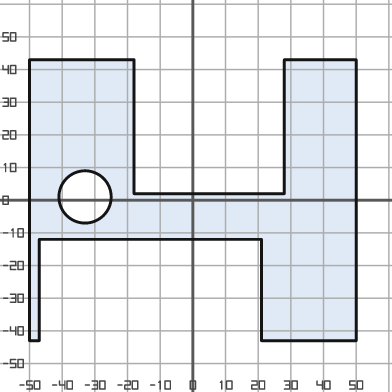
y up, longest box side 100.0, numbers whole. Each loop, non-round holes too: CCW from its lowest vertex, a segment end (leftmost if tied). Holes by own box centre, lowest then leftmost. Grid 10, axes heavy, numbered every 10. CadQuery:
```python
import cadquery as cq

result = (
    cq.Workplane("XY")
    .moveTo(-50.0, -43.0)
    .lineTo(-47.0, -43.0)
    .lineTo(-47.0, -12.0)
    .lineTo(21.0, -12.0)
    .lineTo(21.0, -43.0)
    .lineTo(50.0, -43.0)
    .lineTo(50.0, 43.0)
    .lineTo(28.0, 43.0)
    .lineTo(28.0, 2.0)
    .lineTo(-18.0, 2.0)
    .lineTo(-18.0, 43.0)
    .lineTo(-50.0, 43.0)
    .close()
    .moveTo(-33.0, 1.0)
    .circle(8.0)
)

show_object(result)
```